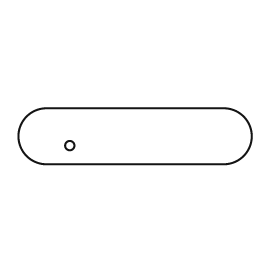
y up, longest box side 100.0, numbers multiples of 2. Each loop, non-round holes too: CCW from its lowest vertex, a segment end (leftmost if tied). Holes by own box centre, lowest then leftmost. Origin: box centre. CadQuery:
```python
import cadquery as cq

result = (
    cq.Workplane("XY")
    .moveTo(-38.0, -12.0)
    .lineTo(38.0, -12.0)
    .threePointArc((50.0, 0.0), (38.0, 12.0))
    .lineTo(-38.0, 12.0)
    .threePointArc((-50.0, 0.0), (-38.0, -12.0))
    .close()
    .moveTo(-28.0, -4.0)
    .circle(2.0)
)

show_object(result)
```